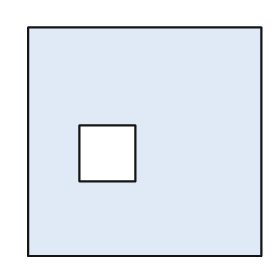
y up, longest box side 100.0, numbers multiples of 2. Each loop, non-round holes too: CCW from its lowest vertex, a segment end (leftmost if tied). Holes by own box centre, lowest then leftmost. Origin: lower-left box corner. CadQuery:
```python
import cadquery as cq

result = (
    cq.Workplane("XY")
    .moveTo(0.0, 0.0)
    .lineTo(100.0, 0.0)
    .lineTo(100.0, 98.0)
    .lineTo(0.0, 98.0)
    .close()
    .moveTo(22.0, 32.0)
    .lineTo(46.0, 32.0)
    .lineTo(46.0, 56.0)
    .lineTo(22.0, 56.0)
    .close()
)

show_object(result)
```